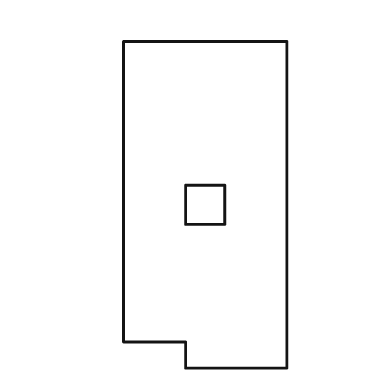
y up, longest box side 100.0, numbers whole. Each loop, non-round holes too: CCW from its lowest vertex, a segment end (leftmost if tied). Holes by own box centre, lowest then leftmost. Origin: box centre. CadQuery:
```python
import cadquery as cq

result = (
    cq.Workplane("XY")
    .moveTo(-6.0, -50.0)
    .lineTo(25.0, -50.0)
    .lineTo(25.0, 50.0)
    .lineTo(-25.0, 50.0)
    .lineTo(-25.0, -42.0)
    .lineTo(-6.0, -42.0)
    .close()
    .moveTo(-6.0, -6.0)
    .lineTo(6.0, -6.0)
    .lineTo(6.0, 6.0)
    .lineTo(-6.0, 6.0)
    .close()
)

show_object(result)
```